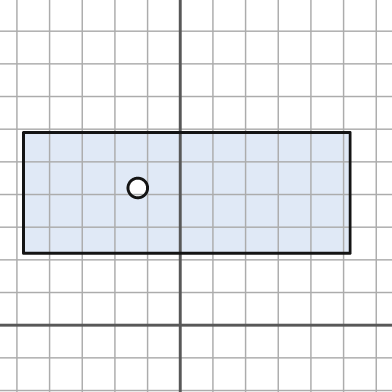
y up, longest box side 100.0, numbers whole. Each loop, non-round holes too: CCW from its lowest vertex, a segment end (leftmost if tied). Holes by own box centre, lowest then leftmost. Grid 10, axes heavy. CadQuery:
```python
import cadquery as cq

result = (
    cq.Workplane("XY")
    .moveTo(-48.0, 22.0)
    .lineTo(52.0, 22.0)
    .lineTo(52.0, 59.0)
    .lineTo(-48.0, 59.0)
    .close()
    .moveTo(-13.0, 42.0)
    .circle(3.0)
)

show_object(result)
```